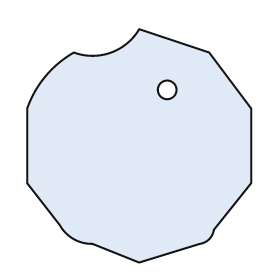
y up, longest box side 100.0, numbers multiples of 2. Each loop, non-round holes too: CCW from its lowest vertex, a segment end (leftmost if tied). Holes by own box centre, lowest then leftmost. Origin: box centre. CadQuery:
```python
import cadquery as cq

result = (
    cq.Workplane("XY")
    .moveTo(0.0, -50.0)
    .lineTo(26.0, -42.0)
    .threePointArc((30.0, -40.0), (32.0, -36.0))
    .lineTo(48.0, -16.0)
    .lineTo(48.0, 16.0)
    .lineTo(30.0, 40.0)
    .lineTo(0.0, 50.0)
    .threePointArc((-12.0, 40.0), (-28.0, 40.0))
    .threePointArc((-40.0, 30.0), (-48.0, 16.0))
    .lineTo(-48.0, -16.0)
    .lineTo(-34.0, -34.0)
    .threePointArc((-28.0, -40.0), (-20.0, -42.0))
    .close()
    .moveTo(12.0, 24.0)
    .circle(4.0)
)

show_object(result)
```